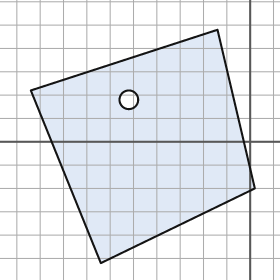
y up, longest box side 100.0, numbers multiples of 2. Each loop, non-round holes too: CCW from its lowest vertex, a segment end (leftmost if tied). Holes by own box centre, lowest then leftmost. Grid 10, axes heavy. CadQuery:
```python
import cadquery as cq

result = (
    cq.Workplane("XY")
    .moveTo(-64.0, -52.0)
    .lineTo(2.0, -20.0)
    .lineTo(-14.0, 48.0)
    .lineTo(-94.0, 22.0)
    .close()
    .moveTo(-52.0, 18.0)
    .circle(4.0)
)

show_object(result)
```